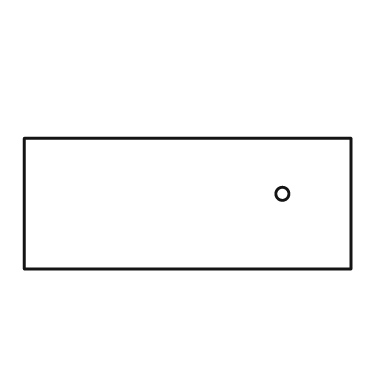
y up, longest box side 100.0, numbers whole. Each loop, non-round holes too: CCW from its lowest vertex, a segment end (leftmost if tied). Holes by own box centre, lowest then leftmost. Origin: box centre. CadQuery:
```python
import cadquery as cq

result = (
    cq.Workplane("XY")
    .moveTo(-50.0, -20.0)
    .lineTo(50.0, -20.0)
    .lineTo(50.0, 20.0)
    .lineTo(-50.0, 20.0)
    .close()
    .moveTo(29.0, 3.0)
    .circle(2.0)
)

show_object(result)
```